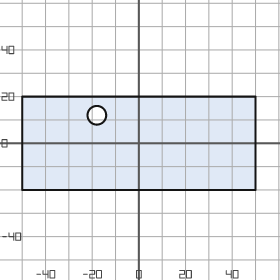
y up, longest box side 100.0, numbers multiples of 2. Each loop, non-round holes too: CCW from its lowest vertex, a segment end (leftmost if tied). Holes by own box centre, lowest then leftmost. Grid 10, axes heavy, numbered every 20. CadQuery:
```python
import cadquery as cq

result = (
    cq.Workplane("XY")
    .moveTo(-50.0, -20.0)
    .lineTo(50.0, -20.0)
    .lineTo(50.0, 20.0)
    .lineTo(-50.0, 20.0)
    .close()
    .moveTo(-18.0, 12.0)
    .circle(4.0)
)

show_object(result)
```